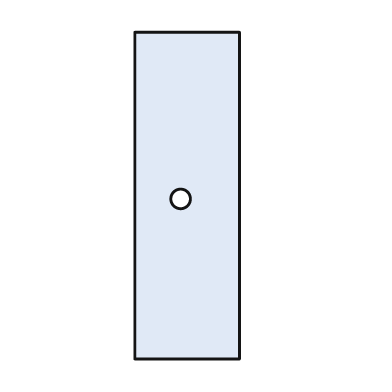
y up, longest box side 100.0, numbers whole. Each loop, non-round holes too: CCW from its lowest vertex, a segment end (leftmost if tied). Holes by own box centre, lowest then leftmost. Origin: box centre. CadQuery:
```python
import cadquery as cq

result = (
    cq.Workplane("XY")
    .moveTo(-16.0, -50.0)
    .lineTo(16.0, -50.0)
    .lineTo(16.0, 50.0)
    .lineTo(-16.0, 50.0)
    .close()
    .moveTo(-2.0, -1.0)
    .circle(3.0)
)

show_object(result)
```